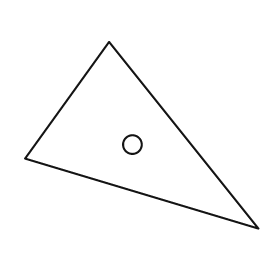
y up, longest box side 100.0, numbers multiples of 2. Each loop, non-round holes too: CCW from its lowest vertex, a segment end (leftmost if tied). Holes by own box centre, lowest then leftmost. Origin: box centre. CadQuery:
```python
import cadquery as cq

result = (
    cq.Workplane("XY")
    .moveTo(50.0, -40.0)
    .lineTo(-14.0, 40.0)
    .lineTo(-50.0, -10.0)
    .close()
    .moveTo(-4.0, -4.0)
    .circle(4.0)
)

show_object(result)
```